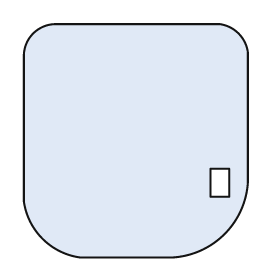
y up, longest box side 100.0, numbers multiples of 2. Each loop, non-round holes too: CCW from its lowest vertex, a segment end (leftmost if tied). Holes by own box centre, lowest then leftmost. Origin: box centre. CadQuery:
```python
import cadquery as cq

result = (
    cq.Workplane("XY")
    .moveTo(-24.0, -50.0)
    .lineTo(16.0, -50.0)
    .threePointArc((38.0, -40.0), (48.0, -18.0))
    .lineTo(48.0, 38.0)
    .threePointArc((44.0, 46.0), (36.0, 50.0))
    .lineTo(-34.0, 50.0)
    .threePointArc((-44.0, 46.0), (-48.0, 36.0))
    .lineTo(-48.0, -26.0)
    .threePointArc((-40.0, -42.0), (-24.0, -50.0))
    .close()
    .moveTo(32.0, -24.0)
    .lineTo(40.0, -24.0)
    .lineTo(40.0, -12.0)
    .lineTo(32.0, -12.0)
    .close()
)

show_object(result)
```